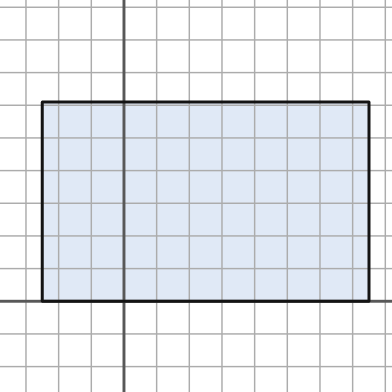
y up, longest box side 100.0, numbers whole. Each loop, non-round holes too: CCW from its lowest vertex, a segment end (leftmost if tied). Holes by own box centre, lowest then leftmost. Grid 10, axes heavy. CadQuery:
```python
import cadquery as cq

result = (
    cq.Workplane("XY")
    .moveTo(-25.0, 0.0)
    .lineTo(75.0, 0.0)
    .lineTo(75.0, 61.0)
    .lineTo(-25.0, 61.0)
    .close()
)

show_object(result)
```